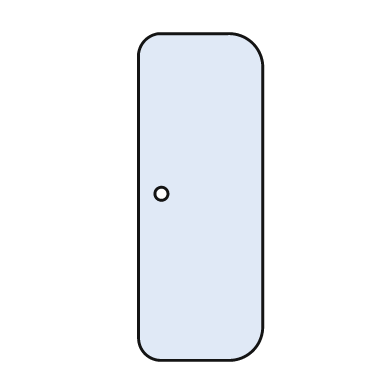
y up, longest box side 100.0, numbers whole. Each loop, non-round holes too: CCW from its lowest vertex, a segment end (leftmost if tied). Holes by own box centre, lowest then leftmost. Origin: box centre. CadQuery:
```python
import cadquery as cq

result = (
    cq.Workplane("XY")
    .moveTo(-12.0, -50.0)
    .lineTo(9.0, -50.0)
    .threePointArc((16.0, -47.0), (19.0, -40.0))
    .lineTo(19.0, 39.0)
    .threePointArc((16.0, 47.0), (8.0, 50.0))
    .lineTo(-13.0, 50.0)
    .threePointArc((-17.0, 48.0), (-19.0, 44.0))
    .lineTo(-19.0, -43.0)
    .threePointArc((-17.0, -48.0), (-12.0, -50.0))
    .close()
    .moveTo(-12.0, 1.0)
    .circle(2.0)
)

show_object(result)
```